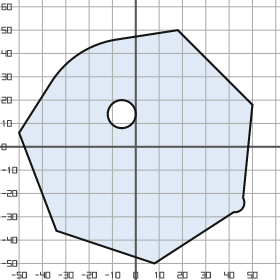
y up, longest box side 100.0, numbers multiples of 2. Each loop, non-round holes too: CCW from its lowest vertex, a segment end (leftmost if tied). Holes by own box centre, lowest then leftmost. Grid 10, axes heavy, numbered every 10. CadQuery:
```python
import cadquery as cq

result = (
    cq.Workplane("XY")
    .moveTo(8.0, -50.0)
    .lineTo(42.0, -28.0)
    .threePointArc((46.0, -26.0), (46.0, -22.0))
    .lineTo(50.0, 18.0)
    .lineTo(18.0, 50.0)
    .lineTo(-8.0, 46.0)
    .threePointArc((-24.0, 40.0), (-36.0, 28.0))
    .lineTo(-50.0, 6.0)
    .lineTo(-34.0, -36.0)
    .close()
    .moveTo(-6.0, 14.0)
    .circle(6.0)
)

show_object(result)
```